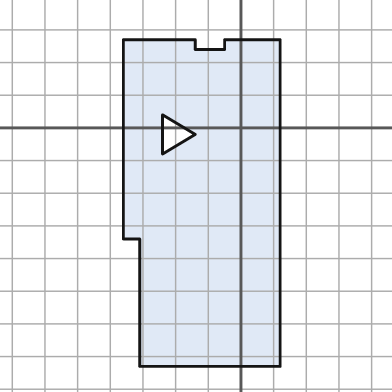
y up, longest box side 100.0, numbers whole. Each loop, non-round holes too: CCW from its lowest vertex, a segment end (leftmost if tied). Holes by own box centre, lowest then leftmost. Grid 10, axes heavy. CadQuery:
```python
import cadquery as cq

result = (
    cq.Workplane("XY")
    .moveTo(-31.0, -73.0)
    .lineTo(12.0, -73.0)
    .lineTo(12.0, 27.0)
    .lineTo(-5.0, 27.0)
    .lineTo(-5.0, 24.0)
    .lineTo(-14.0, 24.0)
    .lineTo(-14.0, 27.0)
    .lineTo(-36.0, 27.0)
    .lineTo(-36.0, -34.0)
    .lineTo(-31.0, -34.0)
    .close()
    .moveTo(-24.0, -8.0)
    .lineTo(-14.0, -2.0)
    .lineTo(-24.0, 4.0)
    .close()
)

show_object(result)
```